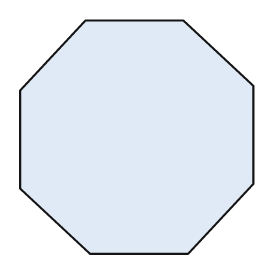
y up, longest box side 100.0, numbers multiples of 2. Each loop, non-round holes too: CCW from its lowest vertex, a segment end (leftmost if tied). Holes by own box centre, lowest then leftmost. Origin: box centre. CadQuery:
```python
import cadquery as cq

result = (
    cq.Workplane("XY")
    .moveTo(-20.0, -50.0)
    .lineTo(22.0, -50.0)
    .lineTo(50.0, -20.0)
    .lineTo(50.0, 22.0)
    .lineTo(20.0, 50.0)
    .lineTo(-22.0, 50.0)
    .lineTo(-50.0, 20.0)
    .lineTo(-50.0, -22.0)
    .close()
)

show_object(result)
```